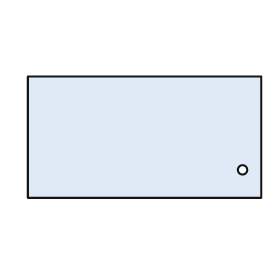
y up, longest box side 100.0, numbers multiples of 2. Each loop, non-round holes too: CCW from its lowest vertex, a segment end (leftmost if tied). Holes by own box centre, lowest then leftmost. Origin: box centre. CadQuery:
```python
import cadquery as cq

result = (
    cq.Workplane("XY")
    .moveTo(-50.0, -26.0)
    .lineTo(50.0, -26.0)
    .lineTo(50.0, 26.0)
    .lineTo(-50.0, 26.0)
    .close()
    .moveTo(42.0, -14.0)
    .circle(2.0)
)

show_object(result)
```